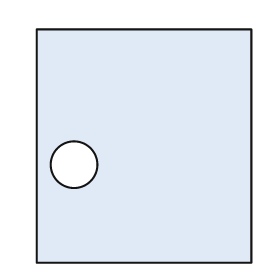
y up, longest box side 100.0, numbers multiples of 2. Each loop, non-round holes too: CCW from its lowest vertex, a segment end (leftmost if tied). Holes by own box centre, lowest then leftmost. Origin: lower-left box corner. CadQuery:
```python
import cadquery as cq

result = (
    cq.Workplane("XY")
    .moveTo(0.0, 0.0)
    .lineTo(92.0, 0.0)
    .lineTo(92.0, 100.0)
    .lineTo(0.0, 100.0)
    .close()
    .moveTo(16.0, 42.0)
    .circle(10.0)
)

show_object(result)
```